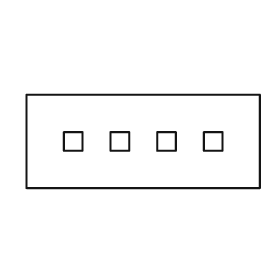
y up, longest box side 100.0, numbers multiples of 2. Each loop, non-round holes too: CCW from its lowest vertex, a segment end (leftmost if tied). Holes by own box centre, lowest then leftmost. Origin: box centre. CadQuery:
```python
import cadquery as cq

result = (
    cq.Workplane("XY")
    .moveTo(-50.0, -20.0)
    .lineTo(50.0, -20.0)
    .lineTo(50.0, 20.0)
    .lineTo(-50.0, 20.0)
    .close()
    .moveTo(-34.0, -4.0)
    .lineTo(-26.0, -4.0)
    .lineTo(-26.0, 4.0)
    .lineTo(-34.0, 4.0)
    .close()
    .moveTo(-14.0, -4.0)
    .lineTo(-6.0, -4.0)
    .lineTo(-6.0, 4.0)
    .lineTo(-14.0, 4.0)
    .close()
    .moveTo(6.0, -4.0)
    .lineTo(14.0, -4.0)
    .lineTo(14.0, 4.0)
    .lineTo(6.0, 4.0)
    .close()
    .moveTo(26.0, -4.0)
    .lineTo(34.0, -4.0)
    .lineTo(34.0, 4.0)
    .lineTo(26.0, 4.0)
    .close()
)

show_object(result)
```